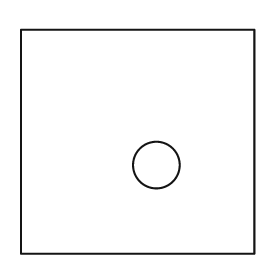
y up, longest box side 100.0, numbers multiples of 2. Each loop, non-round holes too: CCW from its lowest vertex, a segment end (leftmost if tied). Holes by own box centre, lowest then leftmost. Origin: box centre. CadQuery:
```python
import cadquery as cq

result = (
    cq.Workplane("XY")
    .moveTo(-50.0, -48.0)
    .lineTo(50.0, -48.0)
    .lineTo(50.0, 48.0)
    .lineTo(-50.0, 48.0)
    .close()
    .moveTo(8.0, -10.0)
    .circle(10.0)
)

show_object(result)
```